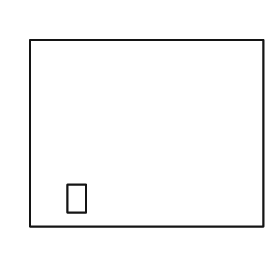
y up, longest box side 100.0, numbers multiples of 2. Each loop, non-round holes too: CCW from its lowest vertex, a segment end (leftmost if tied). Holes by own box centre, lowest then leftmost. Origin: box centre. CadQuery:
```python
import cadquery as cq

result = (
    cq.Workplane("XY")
    .moveTo(-50.0, -40.0)
    .lineTo(50.0, -40.0)
    .lineTo(50.0, 40.0)
    .lineTo(-50.0, 40.0)
    .close()
    .moveTo(-34.0, -34.0)
    .lineTo(-26.0, -34.0)
    .lineTo(-26.0, -22.0)
    .lineTo(-34.0, -22.0)
    .close()
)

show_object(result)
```